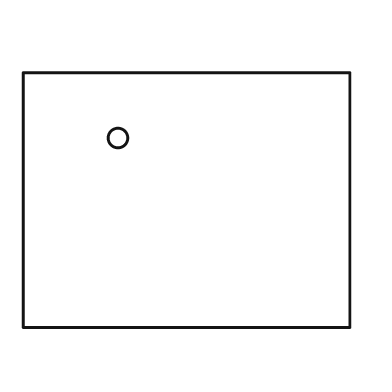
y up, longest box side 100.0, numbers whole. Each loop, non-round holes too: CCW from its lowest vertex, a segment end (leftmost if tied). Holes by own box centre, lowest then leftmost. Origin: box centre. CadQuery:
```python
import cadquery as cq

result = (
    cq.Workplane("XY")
    .moveTo(-50.0, -39.0)
    .lineTo(50.0, -39.0)
    .lineTo(50.0, 39.0)
    .lineTo(-50.0, 39.0)
    .close()
    .moveTo(-21.0, 19.0)
    .circle(3.0)
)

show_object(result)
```